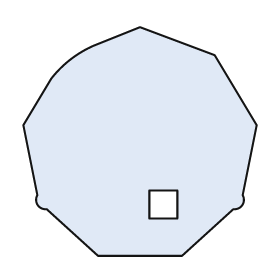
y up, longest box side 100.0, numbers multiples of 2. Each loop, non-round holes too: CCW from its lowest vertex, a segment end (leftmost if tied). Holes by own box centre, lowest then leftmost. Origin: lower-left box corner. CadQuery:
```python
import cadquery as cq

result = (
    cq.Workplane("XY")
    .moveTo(32.0, 0.0)
    .lineTo(68.0, 0.0)
    .lineTo(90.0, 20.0)
    .threePointArc((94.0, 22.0), (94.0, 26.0))
    .lineTo(100.0, 56.0)
    .lineTo(82.0, 86.0)
    .lineTo(50.0, 98.0)
    .lineTo(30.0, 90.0)
    .threePointArc((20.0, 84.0), (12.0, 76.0))
    .lineTo(0.0, 56.0)
    .lineTo(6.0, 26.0)
    .threePointArc((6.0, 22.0), (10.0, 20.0))
    .close()
    .moveTo(54.0, 16.0)
    .lineTo(66.0, 16.0)
    .lineTo(66.0, 28.0)
    .lineTo(54.0, 28.0)
    .close()
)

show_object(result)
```